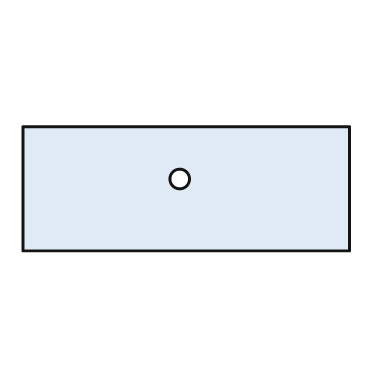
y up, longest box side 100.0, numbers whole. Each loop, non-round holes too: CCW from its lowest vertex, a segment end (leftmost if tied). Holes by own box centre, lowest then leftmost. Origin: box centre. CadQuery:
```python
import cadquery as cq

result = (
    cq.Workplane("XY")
    .moveTo(-50.0, -19.0)
    .lineTo(50.0, -19.0)
    .lineTo(50.0, 19.0)
    .lineTo(-50.0, 19.0)
    .close()
    .moveTo(-2.0, 3.0)
    .circle(3.0)
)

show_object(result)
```